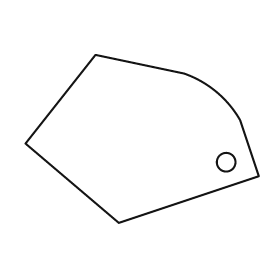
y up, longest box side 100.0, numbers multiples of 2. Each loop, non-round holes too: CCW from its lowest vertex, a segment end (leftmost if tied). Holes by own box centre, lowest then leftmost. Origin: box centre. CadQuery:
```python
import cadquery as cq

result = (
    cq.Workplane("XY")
    .moveTo(-10.0, -36.0)
    .lineTo(50.0, -16.0)
    .lineTo(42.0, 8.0)
    .threePointArc((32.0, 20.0), (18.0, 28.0))
    .lineTo(-20.0, 36.0)
    .lineTo(-50.0, -2.0)
    .close()
    .moveTo(36.0, -10.0)
    .circle(4.0)
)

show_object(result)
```